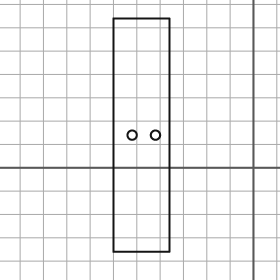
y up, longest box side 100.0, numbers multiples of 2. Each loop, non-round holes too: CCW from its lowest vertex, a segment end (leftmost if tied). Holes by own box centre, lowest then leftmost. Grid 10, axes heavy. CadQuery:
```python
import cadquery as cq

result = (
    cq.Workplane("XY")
    .moveTo(-60.0, -36.0)
    .lineTo(-36.0, -36.0)
    .lineTo(-36.0, 64.0)
    .lineTo(-60.0, 64.0)
    .close()
    .moveTo(-52.0, 14.0)
    .circle(2.0)
    .moveTo(-42.0, 14.0)
    .circle(2.0)
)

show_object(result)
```